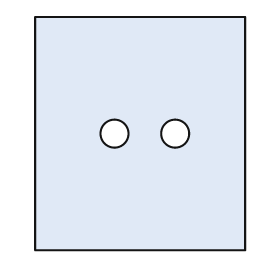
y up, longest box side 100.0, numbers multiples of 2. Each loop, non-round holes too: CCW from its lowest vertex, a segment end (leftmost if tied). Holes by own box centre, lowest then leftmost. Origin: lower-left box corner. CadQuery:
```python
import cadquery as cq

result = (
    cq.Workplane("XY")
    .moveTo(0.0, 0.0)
    .lineTo(90.0, 0.0)
    .lineTo(90.0, 100.0)
    .lineTo(0.0, 100.0)
    .close()
    .moveTo(34.0, 50.0)
    .circle(6.0)
    .moveTo(60.0, 50.0)
    .circle(6.0)
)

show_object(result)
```